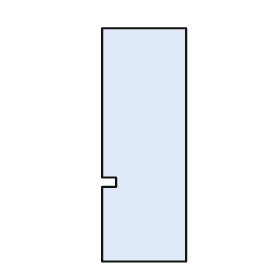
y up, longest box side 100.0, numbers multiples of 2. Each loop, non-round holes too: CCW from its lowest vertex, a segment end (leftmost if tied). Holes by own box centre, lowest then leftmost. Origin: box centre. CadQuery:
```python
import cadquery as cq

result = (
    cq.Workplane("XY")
    .moveTo(-18.0, -50.0)
    .lineTo(18.0, -50.0)
    .lineTo(18.0, 50.0)
    .lineTo(-18.0, 50.0)
    .lineTo(-18.0, -14.0)
    .lineTo(-12.0, -14.0)
    .lineTo(-12.0, -18.0)
    .lineTo(-18.0, -18.0)
    .close()
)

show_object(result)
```